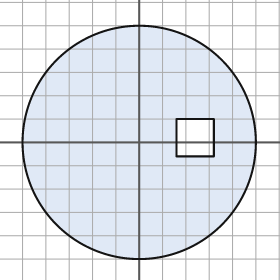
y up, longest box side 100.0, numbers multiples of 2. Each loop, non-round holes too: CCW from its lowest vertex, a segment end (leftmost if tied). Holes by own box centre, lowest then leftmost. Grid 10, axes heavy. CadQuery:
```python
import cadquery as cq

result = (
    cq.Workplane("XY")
    .moveTo(0.0, 0.0)
    .circle(50.0)
    .moveTo(16.0, -6.0)
    .lineTo(32.0, -6.0)
    .lineTo(32.0, 10.0)
    .lineTo(16.0, 10.0)
    .close()
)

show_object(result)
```